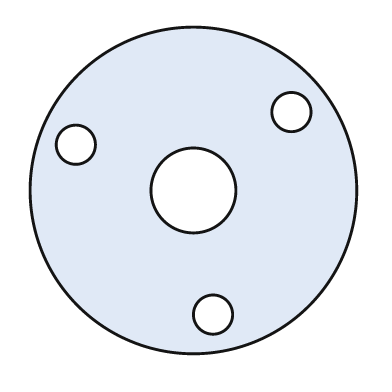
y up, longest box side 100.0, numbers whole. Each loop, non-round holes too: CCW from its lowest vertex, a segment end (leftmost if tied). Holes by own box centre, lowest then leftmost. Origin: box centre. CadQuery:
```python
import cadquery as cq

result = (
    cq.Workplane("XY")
    .moveTo(0.0, 0.0)
    .circle(50.0)
    .moveTo(6.0, -38.0)
    .circle(6.0)
    .moveTo(0.0, 0.0)
    .circle(13.0)
    .moveTo(-36.0, 14.0)
    .circle(6.0)
    .moveTo(30.0, 24.0)
    .circle(6.0)
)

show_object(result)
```